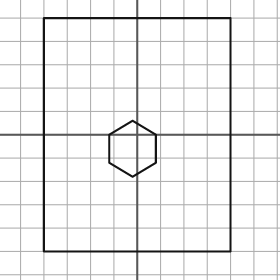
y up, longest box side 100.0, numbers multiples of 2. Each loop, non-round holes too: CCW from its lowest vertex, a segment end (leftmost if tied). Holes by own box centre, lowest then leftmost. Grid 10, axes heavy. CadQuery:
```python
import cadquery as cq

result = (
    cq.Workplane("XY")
    .moveTo(-40.0, -50.0)
    .lineTo(40.0, -50.0)
    .lineTo(40.0, 50.0)
    .lineTo(-40.0, 50.0)
    .close()
    .moveTo(-2.0, -18.0)
    .lineTo(8.0, -12.0)
    .lineTo(8.0, 0.0)
    .lineTo(-2.0, 6.0)
    .lineTo(-12.0, 0.0)
    .lineTo(-12.0, -12.0)
    .close()
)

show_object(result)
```